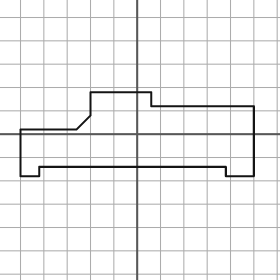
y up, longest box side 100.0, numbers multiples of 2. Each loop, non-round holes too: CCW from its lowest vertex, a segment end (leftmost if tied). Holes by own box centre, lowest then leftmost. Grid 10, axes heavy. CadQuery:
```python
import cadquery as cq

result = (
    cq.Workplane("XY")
    .moveTo(-50.0, -18.0)
    .lineTo(-42.0, -18.0)
    .lineTo(-42.0, -14.0)
    .lineTo(38.0, -14.0)
    .lineTo(38.0, -18.0)
    .lineTo(50.0, -18.0)
    .lineTo(50.0, 12.0)
    .lineTo(6.0, 12.0)
    .lineTo(6.0, 18.0)
    .lineTo(-20.0, 18.0)
    .lineTo(-20.0, 8.0)
    .lineTo(-26.0, 2.0)
    .lineTo(-50.0, 2.0)
    .close()
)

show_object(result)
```